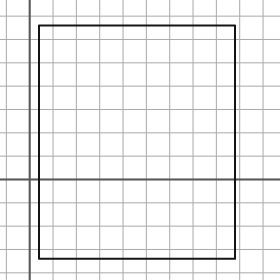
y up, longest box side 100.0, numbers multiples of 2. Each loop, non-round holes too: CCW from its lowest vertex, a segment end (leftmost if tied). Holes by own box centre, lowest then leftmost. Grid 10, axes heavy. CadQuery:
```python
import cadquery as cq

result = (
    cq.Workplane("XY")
    .moveTo(4.0, -34.0)
    .lineTo(88.0, -34.0)
    .lineTo(88.0, 66.0)
    .lineTo(4.0, 66.0)
    .close()
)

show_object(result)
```